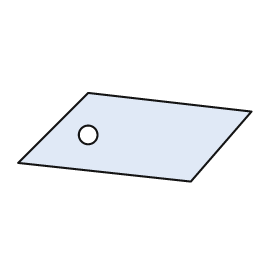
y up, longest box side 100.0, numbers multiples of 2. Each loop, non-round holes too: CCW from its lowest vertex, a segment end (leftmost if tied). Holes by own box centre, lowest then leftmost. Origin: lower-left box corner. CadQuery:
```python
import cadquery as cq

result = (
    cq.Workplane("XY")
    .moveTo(74.0, 0.0)
    .lineTo(100.0, 30.0)
    .lineTo(30.0, 38.0)
    .lineTo(0.0, 8.0)
    .close()
    .moveTo(30.0, 20.0)
    .circle(4.0)
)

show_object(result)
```